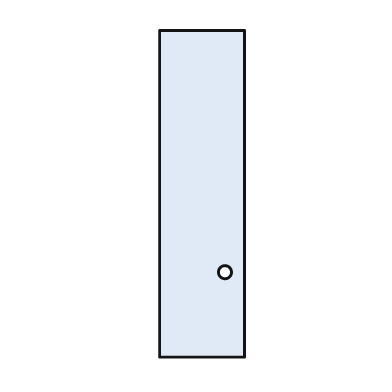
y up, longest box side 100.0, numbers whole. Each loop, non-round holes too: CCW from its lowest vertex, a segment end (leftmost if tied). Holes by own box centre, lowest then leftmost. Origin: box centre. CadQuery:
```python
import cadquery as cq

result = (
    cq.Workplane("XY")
    .moveTo(-13.0, -50.0)
    .lineTo(13.0, -50.0)
    .lineTo(13.0, 50.0)
    .lineTo(-13.0, 50.0)
    .close()
    .moveTo(7.0, -24.0)
    .circle(2.0)
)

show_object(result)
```